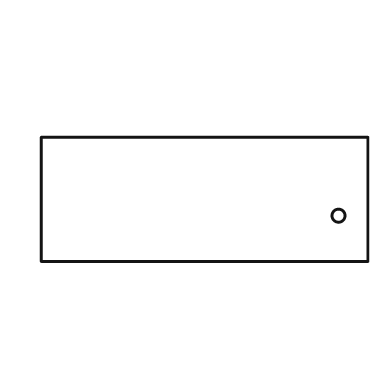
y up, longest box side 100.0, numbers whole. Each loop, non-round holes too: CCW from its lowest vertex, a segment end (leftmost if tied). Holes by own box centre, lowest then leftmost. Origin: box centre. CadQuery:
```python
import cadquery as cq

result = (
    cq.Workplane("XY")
    .moveTo(-50.0, -19.0)
    .lineTo(50.0, -19.0)
    .lineTo(50.0, 19.0)
    .lineTo(-50.0, 19.0)
    .close()
    .moveTo(41.0, -5.0)
    .circle(2.0)
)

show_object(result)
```